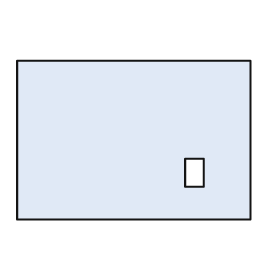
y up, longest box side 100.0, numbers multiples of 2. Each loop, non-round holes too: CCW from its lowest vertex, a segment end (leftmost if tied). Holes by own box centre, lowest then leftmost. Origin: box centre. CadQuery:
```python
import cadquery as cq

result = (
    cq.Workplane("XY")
    .moveTo(-50.0, -34.0)
    .lineTo(50.0, -34.0)
    .lineTo(50.0, 34.0)
    .lineTo(-50.0, 34.0)
    .close()
    .moveTo(22.0, -20.0)
    .lineTo(30.0, -20.0)
    .lineTo(30.0, -8.0)
    .lineTo(22.0, -8.0)
    .close()
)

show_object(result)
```